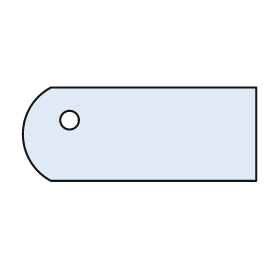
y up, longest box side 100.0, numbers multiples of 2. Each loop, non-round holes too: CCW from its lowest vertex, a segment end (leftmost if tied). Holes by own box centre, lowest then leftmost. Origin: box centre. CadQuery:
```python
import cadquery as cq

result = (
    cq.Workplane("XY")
    .moveTo(-38.0, -20.0)
    .lineTo(50.0, -20.0)
    .lineTo(50.0, 20.0)
    .lineTo(-38.0, 20.0)
    .threePointArc((-50.0, 0.0), (-38.0, -20.0))
    .close()
    .moveTo(-30.0, 6.0)
    .circle(4.0)
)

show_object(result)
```